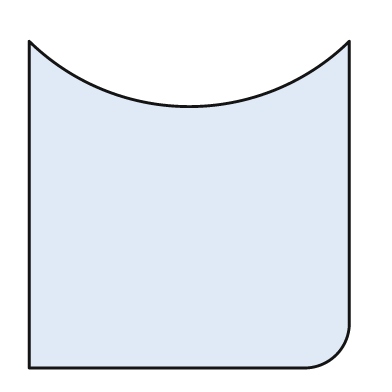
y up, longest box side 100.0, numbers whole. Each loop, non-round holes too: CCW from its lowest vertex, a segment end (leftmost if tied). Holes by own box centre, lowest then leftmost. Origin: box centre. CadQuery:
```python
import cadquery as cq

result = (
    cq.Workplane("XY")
    .moveTo(-49.0, -50.0)
    .lineTo(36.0, -50.0)
    .threePointArc((45.0, -46.0), (49.0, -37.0))
    .lineTo(49.0, 50.0)
    .threePointArc((0.0, 30.0), (-49.0, 50.0))
    .close()
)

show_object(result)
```